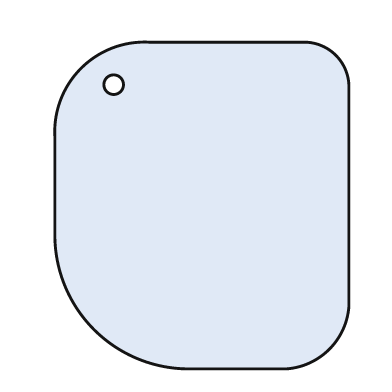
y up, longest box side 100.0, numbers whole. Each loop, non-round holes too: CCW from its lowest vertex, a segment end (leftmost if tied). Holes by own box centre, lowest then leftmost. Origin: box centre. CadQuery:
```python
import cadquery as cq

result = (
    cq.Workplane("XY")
    .moveTo(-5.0, -50.0)
    .lineTo(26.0, -50.0)
    .threePointArc((39.0, -44.0), (45.0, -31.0))
    .lineTo(45.0, 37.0)
    .threePointArc((41.0, 46.0), (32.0, 50.0))
    .lineTo(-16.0, 50.0)
    .threePointArc((-37.0, 42.0), (-45.0, 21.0))
    .lineTo(-45.0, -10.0)
    .threePointArc((-33.0, -38.0), (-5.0, -50.0))
    .close()
    .moveTo(-27.0, 37.0)
    .circle(3.0)
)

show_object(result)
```